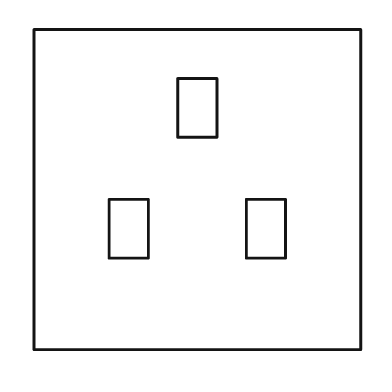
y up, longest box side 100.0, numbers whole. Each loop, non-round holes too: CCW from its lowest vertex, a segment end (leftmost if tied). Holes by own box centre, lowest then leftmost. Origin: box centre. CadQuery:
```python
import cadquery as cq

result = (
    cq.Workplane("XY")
    .moveTo(-50.0, -49.0)
    .lineTo(50.0, -49.0)
    .lineTo(50.0, 49.0)
    .lineTo(-50.0, 49.0)
    .close()
    .moveTo(-27.0, -21.0)
    .lineTo(-15.0, -21.0)
    .lineTo(-15.0, -3.0)
    .lineTo(-27.0, -3.0)
    .close()
    .moveTo(15.0, -21.0)
    .lineTo(27.0, -21.0)
    .lineTo(27.0, -3.0)
    .lineTo(15.0, -3.0)
    .close()
    .moveTo(-6.0, 16.0)
    .lineTo(6.0, 16.0)
    .lineTo(6.0, 34.0)
    .lineTo(-6.0, 34.0)
    .close()
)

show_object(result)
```